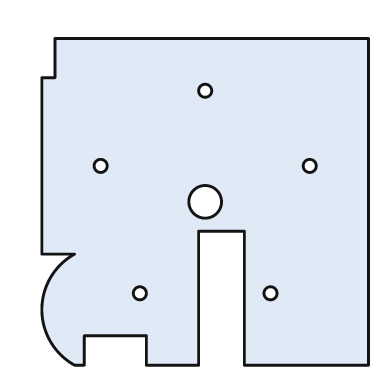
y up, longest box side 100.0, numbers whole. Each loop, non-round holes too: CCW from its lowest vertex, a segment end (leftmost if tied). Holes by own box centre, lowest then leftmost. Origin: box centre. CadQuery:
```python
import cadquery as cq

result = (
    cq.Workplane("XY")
    .moveTo(-40.0, -50.0)
    .lineTo(-37.0, -50.0)
    .lineTo(-37.0, -41.0)
    .lineTo(-18.0, -41.0)
    .lineTo(-18.0, -50.0)
    .lineTo(-2.0, -50.0)
    .lineTo(-2.0, -9.0)
    .lineTo(12.0, -9.0)
    .lineTo(12.0, -50.0)
    .lineTo(50.0, -50.0)
    .lineTo(50.0, 50.0)
    .lineTo(-46.0, 50.0)
    .lineTo(-46.0, 38.0)
    .lineTo(-50.0, 38.0)
    .lineTo(-50.0, -16.0)
    .lineTo(-40.0, -16.0)
    .threePointArc((-50.0, -33.0), (-40.0, -50.0))
    .close()
    .moveTo(-20.0, -28.0)
    .circle(2.0)
    .moveTo(20.0, -28.0)
    .circle(2.0)
    .moveTo(0.0, 0.0)
    .circle(5.0)
    .moveTo(-32.0, 11.0)
    .circle(2.0)
    .moveTo(32.0, 11.0)
    .circle(2.0)
    .moveTo(0.0, 34.0)
    .circle(2.0)
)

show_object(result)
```